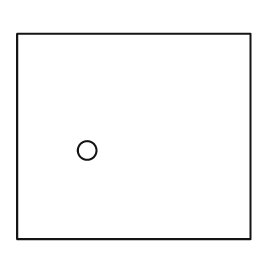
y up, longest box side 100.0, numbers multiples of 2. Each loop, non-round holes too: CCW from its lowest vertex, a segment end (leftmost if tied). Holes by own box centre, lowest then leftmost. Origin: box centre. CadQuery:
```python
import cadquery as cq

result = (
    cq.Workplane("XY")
    .moveTo(-50.0, -44.0)
    .lineTo(50.0, -44.0)
    .lineTo(50.0, 44.0)
    .lineTo(-50.0, 44.0)
    .close()
    .moveTo(-20.0, -6.0)
    .circle(4.0)
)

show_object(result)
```